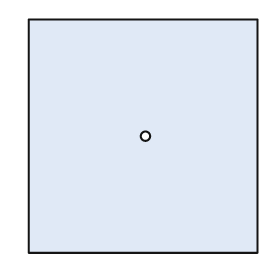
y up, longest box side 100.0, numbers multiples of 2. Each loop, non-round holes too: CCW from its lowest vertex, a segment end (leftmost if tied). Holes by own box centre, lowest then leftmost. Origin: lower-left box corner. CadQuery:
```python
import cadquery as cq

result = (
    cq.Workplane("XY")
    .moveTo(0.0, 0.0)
    .lineTo(98.0, 0.0)
    .lineTo(98.0, 100.0)
    .lineTo(0.0, 100.0)
    .close()
    .moveTo(50.0, 50.0)
    .circle(2.0)
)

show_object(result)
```